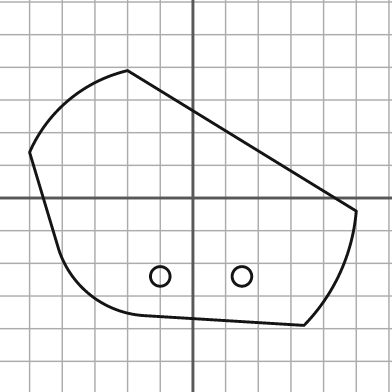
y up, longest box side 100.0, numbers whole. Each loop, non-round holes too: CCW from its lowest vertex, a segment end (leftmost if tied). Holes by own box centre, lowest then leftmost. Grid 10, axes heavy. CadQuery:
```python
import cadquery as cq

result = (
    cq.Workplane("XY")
    .moveTo(34.0, -39.0)
    .threePointArc((45.0, -23.0), (50.0, -4.0))
    .lineTo(-20.0, 39.0)
    .threePointArc((-38.0, 30.0), (-50.0, 14.0))
    .lineTo(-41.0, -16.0)
    .threePointArc((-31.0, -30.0), (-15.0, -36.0))
    .close()
    .moveTo(-10.0, -24.0)
    .circle(3.0)
    .moveTo(15.0, -24.0)
    .circle(3.0)
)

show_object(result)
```